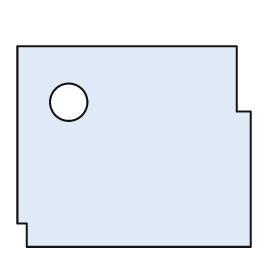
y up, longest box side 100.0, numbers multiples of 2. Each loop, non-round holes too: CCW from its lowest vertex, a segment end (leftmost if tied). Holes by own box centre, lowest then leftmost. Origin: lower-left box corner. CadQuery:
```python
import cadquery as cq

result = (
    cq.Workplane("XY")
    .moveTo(4.0, 0.0)
    .lineTo(100.0, 0.0)
    .lineTo(100.0, 58.0)
    .lineTo(94.0, 58.0)
    .lineTo(94.0, 86.0)
    .lineTo(0.0, 86.0)
    .lineTo(0.0, 10.0)
    .lineTo(4.0, 10.0)
    .close()
    .moveTo(22.0, 62.0)
    .circle(8.0)
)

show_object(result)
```